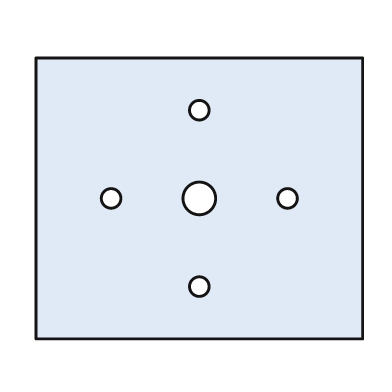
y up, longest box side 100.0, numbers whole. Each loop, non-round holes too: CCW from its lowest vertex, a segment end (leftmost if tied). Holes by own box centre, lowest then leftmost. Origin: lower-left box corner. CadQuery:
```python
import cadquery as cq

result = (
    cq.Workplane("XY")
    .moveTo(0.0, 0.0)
    .lineTo(100.0, 0.0)
    .lineTo(100.0, 86.0)
    .lineTo(0.0, 86.0)
    .close()
    .moveTo(50.0, 16.0)
    .circle(3.0)
    .moveTo(23.0, 43.0)
    .circle(3.0)
    .moveTo(50.0, 43.0)
    .circle(5.0)
    .moveTo(77.0, 43.0)
    .circle(3.0)
    .moveTo(50.0, 70.0)
    .circle(3.0)
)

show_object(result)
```